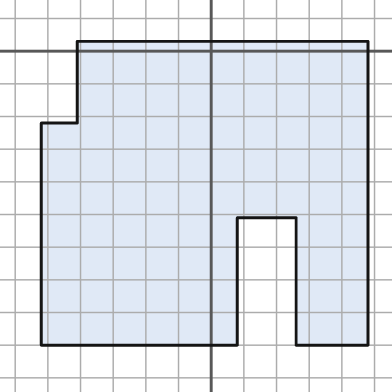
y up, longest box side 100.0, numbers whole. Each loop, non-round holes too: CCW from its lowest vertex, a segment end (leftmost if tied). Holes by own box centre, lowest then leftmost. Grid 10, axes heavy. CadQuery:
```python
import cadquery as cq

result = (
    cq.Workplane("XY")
    .moveTo(-52.0, -90.0)
    .lineTo(8.0, -90.0)
    .lineTo(8.0, -51.0)
    .lineTo(26.0, -51.0)
    .lineTo(26.0, -90.0)
    .lineTo(48.0, -90.0)
    .lineTo(48.0, 3.0)
    .lineTo(-41.0, 3.0)
    .lineTo(-41.0, -22.0)
    .lineTo(-52.0, -22.0)
    .close()
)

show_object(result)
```